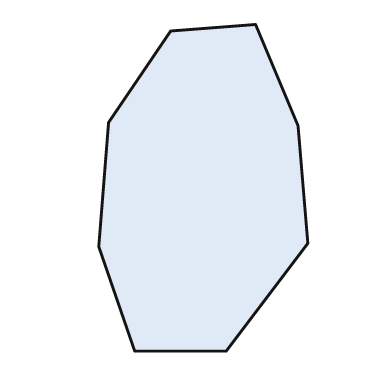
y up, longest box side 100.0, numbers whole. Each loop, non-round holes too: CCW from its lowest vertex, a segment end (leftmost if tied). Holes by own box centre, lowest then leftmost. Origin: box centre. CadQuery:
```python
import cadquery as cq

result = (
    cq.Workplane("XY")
    .moveTo(-21.0, -50.0)
    .lineTo(7.0, -50.0)
    .lineTo(32.0, -17.0)
    .lineTo(29.0, 19.0)
    .lineTo(16.0, 50.0)
    .lineTo(-10.0, 48.0)
    .lineTo(-29.0, 20.0)
    .lineTo(-32.0, -18.0)
    .close()
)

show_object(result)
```